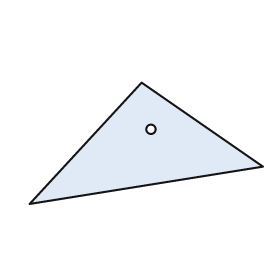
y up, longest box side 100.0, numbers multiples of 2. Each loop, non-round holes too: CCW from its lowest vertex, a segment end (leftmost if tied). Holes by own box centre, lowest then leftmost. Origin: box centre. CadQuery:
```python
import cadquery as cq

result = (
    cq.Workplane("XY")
    .moveTo(-50.0, -26.0)
    .lineTo(50.0, -10.0)
    .lineTo(-2.0, 26.0)
    .close()
    .moveTo(2.0, 6.0)
    .circle(2.0)
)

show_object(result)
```